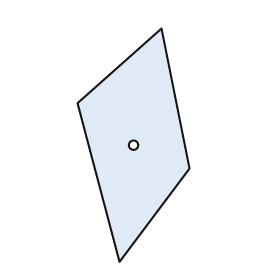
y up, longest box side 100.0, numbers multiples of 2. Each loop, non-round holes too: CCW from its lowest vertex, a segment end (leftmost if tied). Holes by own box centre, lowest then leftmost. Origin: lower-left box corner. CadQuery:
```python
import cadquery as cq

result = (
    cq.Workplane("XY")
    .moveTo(18.0, 0.0)
    .lineTo(48.0, 40.0)
    .lineTo(36.0, 100.0)
    .lineTo(0.0, 68.0)
    .close()
    .moveTo(24.0, 50.0)
    .circle(2.0)
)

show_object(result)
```